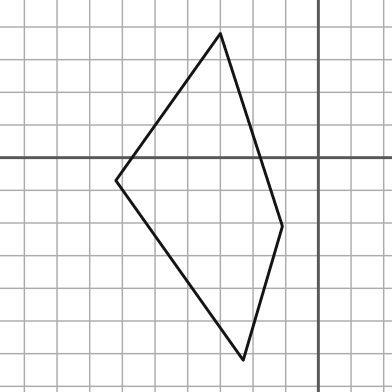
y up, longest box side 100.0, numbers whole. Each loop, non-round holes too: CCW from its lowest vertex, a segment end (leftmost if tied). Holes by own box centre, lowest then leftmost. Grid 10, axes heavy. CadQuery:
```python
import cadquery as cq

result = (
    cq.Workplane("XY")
    .moveTo(-23.0, -62.0)
    .lineTo(-11.0, -21.0)
    .lineTo(-30.0, 38.0)
    .lineTo(-62.0, -7.0)
    .close()
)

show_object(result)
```